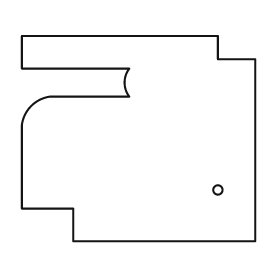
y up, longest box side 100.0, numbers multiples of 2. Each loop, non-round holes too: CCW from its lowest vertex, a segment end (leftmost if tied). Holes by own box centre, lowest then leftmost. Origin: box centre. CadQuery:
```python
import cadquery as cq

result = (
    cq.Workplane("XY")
    .moveTo(-28.0, -44.0)
    .lineTo(50.0, -44.0)
    .lineTo(50.0, 34.0)
    .lineTo(34.0, 34.0)
    .lineTo(34.0, 44.0)
    .lineTo(-50.0, 44.0)
    .lineTo(-50.0, 30.0)
    .lineTo(-4.0, 30.0)
    .threePointArc((-6.0, 24.0), (-4.0, 18.0))
    .lineTo(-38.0, 18.0)
    .threePointArc((-46.0, 14.0), (-50.0, 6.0))
    .lineTo(-50.0, -30.0)
    .lineTo(-28.0, -30.0)
    .close()
    .moveTo(34.0, -22.0)
    .circle(2.0)
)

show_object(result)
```